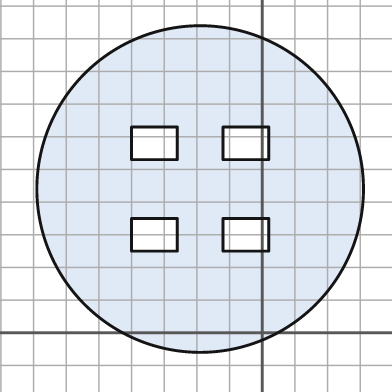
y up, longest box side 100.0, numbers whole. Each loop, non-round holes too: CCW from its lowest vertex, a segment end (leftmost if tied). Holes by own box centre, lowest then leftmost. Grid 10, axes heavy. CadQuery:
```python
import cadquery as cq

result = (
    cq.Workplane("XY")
    .moveTo(-19.0, 44.0)
    .circle(50.0)
    .moveTo(-40.0, 25.0)
    .lineTo(-26.0, 25.0)
    .lineTo(-26.0, 35.0)
    .lineTo(-40.0, 35.0)
    .close()
    .moveTo(-12.0, 25.0)
    .lineTo(2.0, 25.0)
    .lineTo(2.0, 35.0)
    .lineTo(-12.0, 35.0)
    .close()
    .moveTo(-40.0, 53.0)
    .lineTo(-26.0, 53.0)
    .lineTo(-26.0, 63.0)
    .lineTo(-40.0, 63.0)
    .close()
    .moveTo(-12.0, 53.0)
    .lineTo(2.0, 53.0)
    .lineTo(2.0, 63.0)
    .lineTo(-12.0, 63.0)
    .close()
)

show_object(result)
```